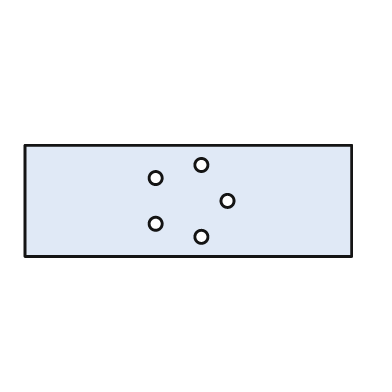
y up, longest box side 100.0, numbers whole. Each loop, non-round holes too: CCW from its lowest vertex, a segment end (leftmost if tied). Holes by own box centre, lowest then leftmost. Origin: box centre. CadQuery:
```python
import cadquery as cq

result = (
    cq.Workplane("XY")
    .moveTo(-50.0, -17.0)
    .lineTo(50.0, -17.0)
    .lineTo(50.0, 17.0)
    .lineTo(-50.0, 17.0)
    .close()
    .moveTo(4.0, -11.0)
    .circle(2.0)
    .moveTo(-10.0, -7.0)
    .circle(2.0)
    .moveTo(12.0, 0.0)
    .circle(2.0)
    .moveTo(-10.0, 7.0)
    .circle(2.0)
    .moveTo(4.0, 11.0)
    .circle(2.0)
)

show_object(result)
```